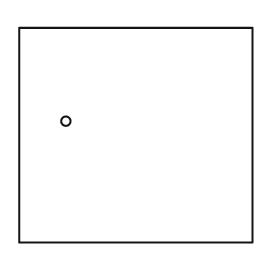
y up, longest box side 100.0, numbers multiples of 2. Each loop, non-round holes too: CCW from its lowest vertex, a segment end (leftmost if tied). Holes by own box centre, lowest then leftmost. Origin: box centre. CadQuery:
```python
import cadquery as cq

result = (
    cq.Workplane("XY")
    .moveTo(-50.0, -46.0)
    .lineTo(50.0, -46.0)
    .lineTo(50.0, 46.0)
    .lineTo(-50.0, 46.0)
    .close()
    .moveTo(-30.0, 6.0)
    .circle(2.0)
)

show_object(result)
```